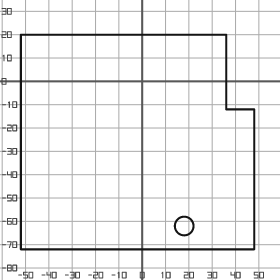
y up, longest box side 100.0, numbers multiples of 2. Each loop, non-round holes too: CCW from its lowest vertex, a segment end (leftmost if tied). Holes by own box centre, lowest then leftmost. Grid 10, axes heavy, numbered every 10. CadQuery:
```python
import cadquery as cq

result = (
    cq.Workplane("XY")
    .moveTo(-52.0, -72.0)
    .lineTo(48.0, -72.0)
    .lineTo(48.0, -12.0)
    .lineTo(36.0, -12.0)
    .lineTo(36.0, 20.0)
    .lineTo(-52.0, 20.0)
    .close()
    .moveTo(18.0, -62.0)
    .circle(4.0)
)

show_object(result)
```